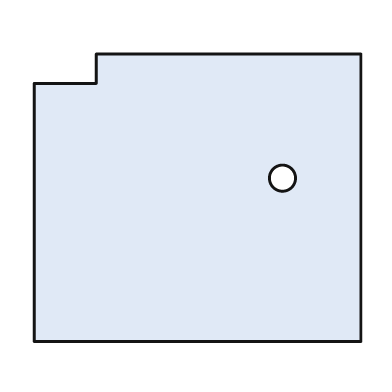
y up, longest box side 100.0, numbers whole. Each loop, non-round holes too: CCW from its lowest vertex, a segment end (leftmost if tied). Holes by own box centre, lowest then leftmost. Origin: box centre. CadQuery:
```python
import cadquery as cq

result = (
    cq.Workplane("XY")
    .moveTo(-50.0, -44.0)
    .lineTo(50.0, -44.0)
    .lineTo(50.0, 44.0)
    .lineTo(-31.0, 44.0)
    .lineTo(-31.0, 35.0)
    .lineTo(-50.0, 35.0)
    .close()
    .moveTo(26.0, 6.0)
    .circle(4.0)
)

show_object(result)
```